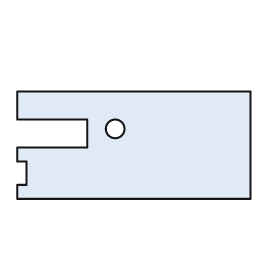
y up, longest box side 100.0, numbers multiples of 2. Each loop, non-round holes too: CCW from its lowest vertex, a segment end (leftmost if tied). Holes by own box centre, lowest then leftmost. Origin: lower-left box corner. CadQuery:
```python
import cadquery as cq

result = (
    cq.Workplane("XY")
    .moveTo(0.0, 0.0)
    .lineTo(100.0, 0.0)
    .lineTo(100.0, 46.0)
    .lineTo(0.0, 46.0)
    .lineTo(0.0, 34.0)
    .lineTo(30.0, 34.0)
    .lineTo(30.0, 22.0)
    .lineTo(0.0, 22.0)
    .lineTo(0.0, 16.0)
    .lineTo(4.0, 16.0)
    .lineTo(4.0, 6.0)
    .lineTo(0.0, 6.0)
    .close()
    .moveTo(42.0, 30.0)
    .circle(4.0)
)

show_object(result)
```